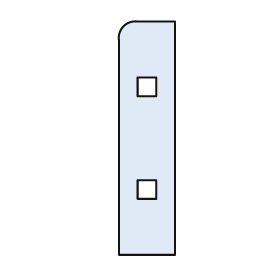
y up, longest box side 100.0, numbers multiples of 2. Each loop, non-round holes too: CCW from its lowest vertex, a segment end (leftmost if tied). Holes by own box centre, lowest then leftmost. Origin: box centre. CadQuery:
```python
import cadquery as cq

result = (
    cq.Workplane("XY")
    .moveTo(-12.0, -50.0)
    .lineTo(12.0, -50.0)
    .lineTo(12.0, 50.0)
    .lineTo(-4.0, 50.0)
    .threePointArc((-10.0, 48.0), (-12.0, 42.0))
    .close()
    .moveTo(-4.0, -26.0)
    .lineTo(4.0, -26.0)
    .lineTo(4.0, -18.0)
    .lineTo(-4.0, -18.0)
    .close()
    .moveTo(-4.0, 18.0)
    .lineTo(4.0, 18.0)
    .lineTo(4.0, 26.0)
    .lineTo(-4.0, 26.0)
    .close()
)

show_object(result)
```